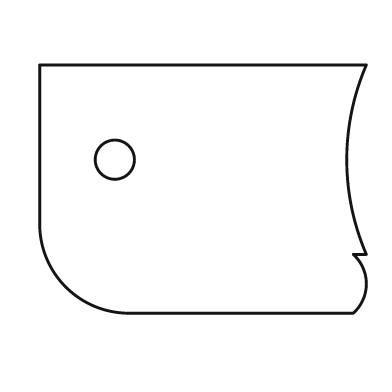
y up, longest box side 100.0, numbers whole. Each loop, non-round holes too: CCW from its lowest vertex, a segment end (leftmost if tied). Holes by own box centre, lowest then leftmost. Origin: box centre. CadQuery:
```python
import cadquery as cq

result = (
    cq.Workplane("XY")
    .moveTo(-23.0, -38.0)
    .lineTo(46.0, -38.0)
    .threePointArc((50.0, -29.0), (46.0, -20.0))
    .lineTo(50.0, -20.0)
    .threePointArc((44.0, 9.0), (50.0, 38.0))
    .lineTo(-50.0, 38.0)
    .lineTo(-50.0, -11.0)
    .threePointArc((-42.0, -30.0), (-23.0, -38.0))
    .close()
    .moveTo(-27.0, 9.0)
    .circle(6.0)
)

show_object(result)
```